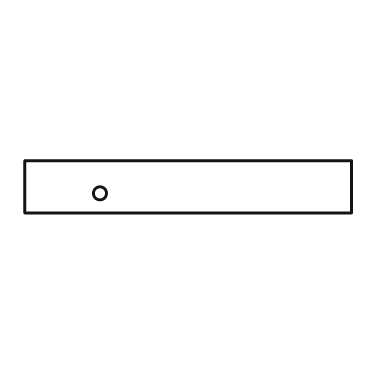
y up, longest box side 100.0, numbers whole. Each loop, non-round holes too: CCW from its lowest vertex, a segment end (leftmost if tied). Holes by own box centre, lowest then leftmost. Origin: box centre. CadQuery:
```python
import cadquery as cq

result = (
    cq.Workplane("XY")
    .moveTo(-50.0, -8.0)
    .lineTo(50.0, -8.0)
    .lineTo(50.0, 8.0)
    .lineTo(-50.0, 8.0)
    .close()
    .moveTo(-27.0, -2.0)
    .circle(2.0)
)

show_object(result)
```